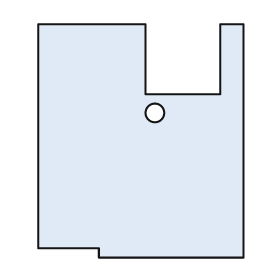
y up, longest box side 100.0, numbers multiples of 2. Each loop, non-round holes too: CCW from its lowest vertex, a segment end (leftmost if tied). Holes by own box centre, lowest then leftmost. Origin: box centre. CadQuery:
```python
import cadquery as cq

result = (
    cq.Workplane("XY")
    .moveTo(-18.0, -50.0)
    .lineTo(44.0, -50.0)
    .lineTo(44.0, 50.0)
    .lineTo(34.0, 50.0)
    .lineTo(34.0, 20.0)
    .lineTo(2.0, 20.0)
    .lineTo(2.0, 50.0)
    .lineTo(-44.0, 50.0)
    .lineTo(-44.0, -46.0)
    .lineTo(-18.0, -46.0)
    .close()
    .moveTo(6.0, 12.0)
    .circle(4.0)
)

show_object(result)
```